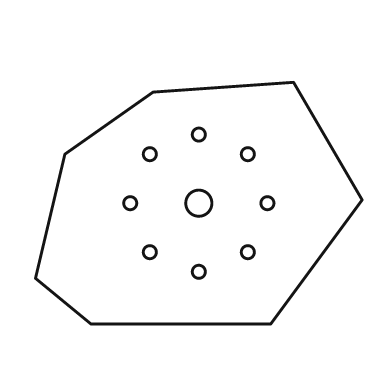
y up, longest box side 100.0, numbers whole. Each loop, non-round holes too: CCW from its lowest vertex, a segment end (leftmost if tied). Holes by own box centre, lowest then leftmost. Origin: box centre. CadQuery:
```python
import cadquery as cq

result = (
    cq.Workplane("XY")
    .moveTo(-33.0, -37.0)
    .lineTo(22.0, -37.0)
    .lineTo(50.0, 1.0)
    .lineTo(29.0, 37.0)
    .lineTo(-14.0, 34.0)
    .lineTo(-41.0, 15.0)
    .lineTo(-50.0, -23.0)
    .close()
    .moveTo(0.0, -21.0)
    .circle(2.0)
    .moveTo(-15.0, -15.0)
    .circle(2.0)
    .moveTo(15.0, -15.0)
    .circle(2.0)
    .moveTo(-21.0, 0.0)
    .circle(2.0)
    .moveTo(0.0, 0.0)
    .circle(4.0)
    .moveTo(21.0, 0.0)
    .circle(2.0)
    .moveTo(-15.0, 15.0)
    .circle(2.0)
    .moveTo(15.0, 15.0)
    .circle(2.0)
    .moveTo(0.0, 21.0)
    .circle(2.0)
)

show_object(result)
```